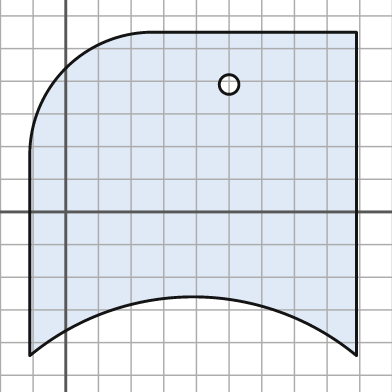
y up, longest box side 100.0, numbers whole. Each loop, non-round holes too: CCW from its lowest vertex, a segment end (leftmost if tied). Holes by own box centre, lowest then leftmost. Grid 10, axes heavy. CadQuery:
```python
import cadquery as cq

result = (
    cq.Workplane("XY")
    .moveTo(-11.0, -44.0)
    .threePointArc((39.0, -26.0), (89.0, -44.0))
    .lineTo(89.0, 55.0)
    .lineTo(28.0, 55.0)
    .threePointArc((0.0, 44.0), (-11.0, 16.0))
    .close()
    .moveTo(50.0, 39.0)
    .circle(3.0)
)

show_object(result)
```